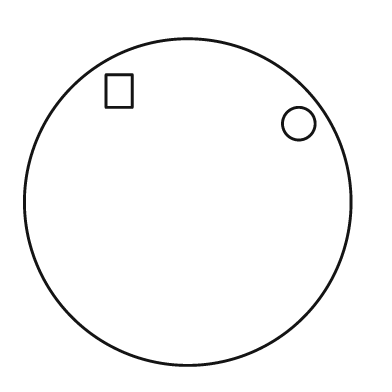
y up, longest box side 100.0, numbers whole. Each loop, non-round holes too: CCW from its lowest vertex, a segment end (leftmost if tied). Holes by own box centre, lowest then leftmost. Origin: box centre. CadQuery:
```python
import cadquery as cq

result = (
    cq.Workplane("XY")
    .moveTo(0.0, 0.0)
    .circle(50.0)
    .moveTo(34.0, 24.0)
    .circle(5.0)
    .moveTo(-25.0, 29.0)
    .lineTo(-17.0, 29.0)
    .lineTo(-17.0, 39.0)
    .lineTo(-25.0, 39.0)
    .close()
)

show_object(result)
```